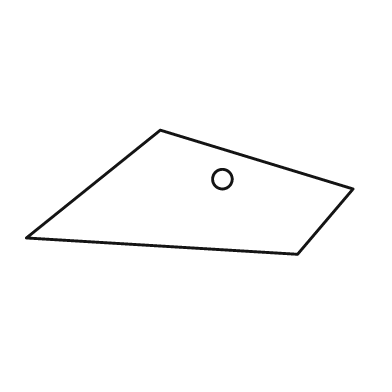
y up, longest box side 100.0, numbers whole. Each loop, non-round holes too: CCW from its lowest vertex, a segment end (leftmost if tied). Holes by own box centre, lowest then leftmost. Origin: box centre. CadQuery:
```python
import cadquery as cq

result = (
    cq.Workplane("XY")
    .moveTo(33.0, -19.0)
    .lineTo(50.0, 1.0)
    .lineTo(-9.0, 19.0)
    .lineTo(-50.0, -14.0)
    .close()
    .moveTo(10.0, 4.0)
    .circle(3.0)
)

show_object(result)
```